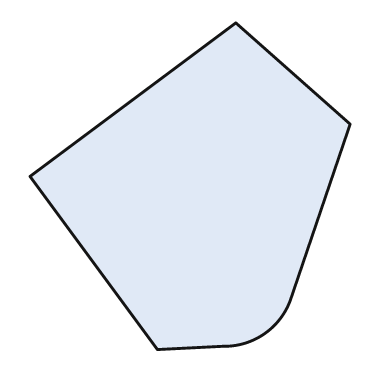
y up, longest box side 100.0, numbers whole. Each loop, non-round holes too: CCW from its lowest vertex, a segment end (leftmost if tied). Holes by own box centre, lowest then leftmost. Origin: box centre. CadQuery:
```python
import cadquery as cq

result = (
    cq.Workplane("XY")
    .moveTo(-10.0, -50.0)
    .lineTo(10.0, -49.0)
    .threePointArc((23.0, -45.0), (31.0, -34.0))
    .lineTo(49.0, 19.0)
    .lineTo(14.0, 50.0)
    .lineTo(-49.0, 3.0)
    .close()
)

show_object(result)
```